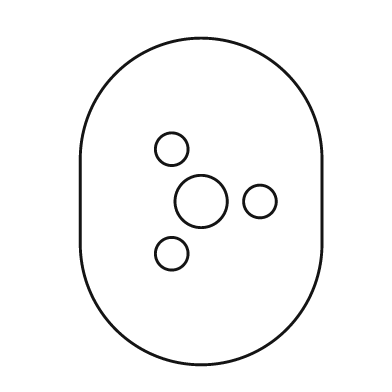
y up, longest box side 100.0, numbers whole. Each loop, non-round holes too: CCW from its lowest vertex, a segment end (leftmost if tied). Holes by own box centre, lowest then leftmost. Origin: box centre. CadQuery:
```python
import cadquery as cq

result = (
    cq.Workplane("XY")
    .moveTo(-37.0, -13.0)
    .threePointArc((0.0, -50.0), (37.0, -13.0))
    .lineTo(37.0, 13.0)
    .threePointArc((0.0, 50.0), (-37.0, 13.0))
    .close()
    .moveTo(-9.0, -16.0)
    .circle(5.0)
    .moveTo(0.0, 0.0)
    .circle(8.0)
    .moveTo(18.0, 0.0)
    .circle(5.0)
    .moveTo(-9.0, 16.0)
    .circle(5.0)
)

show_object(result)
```